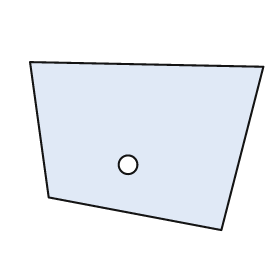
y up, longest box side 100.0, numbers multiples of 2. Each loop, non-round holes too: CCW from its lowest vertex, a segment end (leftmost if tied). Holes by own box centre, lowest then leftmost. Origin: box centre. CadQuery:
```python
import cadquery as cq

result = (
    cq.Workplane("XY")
    .moveTo(32.0, -36.0)
    .lineTo(50.0, 34.0)
    .lineTo(-50.0, 36.0)
    .lineTo(-42.0, -22.0)
    .close()
    .moveTo(-8.0, -8.0)
    .circle(4.0)
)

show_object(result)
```